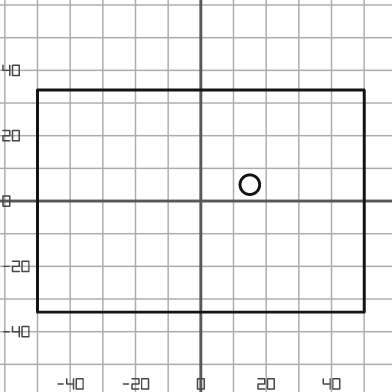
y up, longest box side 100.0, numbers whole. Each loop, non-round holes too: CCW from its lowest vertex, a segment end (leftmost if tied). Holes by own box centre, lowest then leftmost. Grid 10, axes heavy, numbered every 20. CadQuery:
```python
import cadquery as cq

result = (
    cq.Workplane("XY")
    .moveTo(-50.0, -34.0)
    .lineTo(50.0, -34.0)
    .lineTo(50.0, 34.0)
    .lineTo(-50.0, 34.0)
    .close()
    .moveTo(15.0, 5.0)
    .circle(3.0)
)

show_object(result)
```